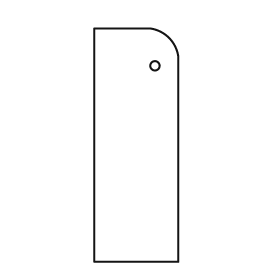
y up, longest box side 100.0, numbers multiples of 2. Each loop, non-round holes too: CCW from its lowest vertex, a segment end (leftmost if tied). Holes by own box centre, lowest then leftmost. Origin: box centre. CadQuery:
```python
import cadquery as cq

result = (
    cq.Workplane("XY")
    .moveTo(-18.0, -50.0)
    .lineTo(18.0, -50.0)
    .lineTo(18.0, 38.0)
    .threePointArc((14.0, 46.0), (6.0, 50.0))
    .lineTo(-18.0, 50.0)
    .close()
    .moveTo(8.0, 34.0)
    .circle(2.0)
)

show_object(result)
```